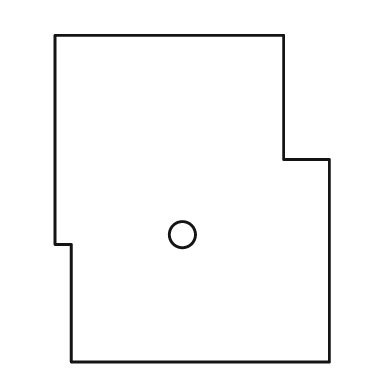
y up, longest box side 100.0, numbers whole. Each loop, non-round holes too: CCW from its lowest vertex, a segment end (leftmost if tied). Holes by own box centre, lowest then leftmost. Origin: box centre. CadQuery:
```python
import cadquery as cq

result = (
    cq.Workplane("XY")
    .moveTo(-37.0, -50.0)
    .lineTo(42.0, -50.0)
    .lineTo(42.0, 12.0)
    .lineTo(28.0, 12.0)
    .lineTo(28.0, 50.0)
    .lineTo(-42.0, 50.0)
    .lineTo(-42.0, -14.0)
    .lineTo(-37.0, -14.0)
    .close()
    .moveTo(-3.0, -11.0)
    .circle(4.0)
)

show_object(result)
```